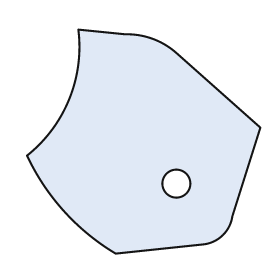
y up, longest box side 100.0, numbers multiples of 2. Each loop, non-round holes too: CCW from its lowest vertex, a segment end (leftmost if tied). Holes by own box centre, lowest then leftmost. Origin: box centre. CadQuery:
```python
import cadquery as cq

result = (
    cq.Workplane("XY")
    .moveTo(-12.0, -48.0)
    .lineTo(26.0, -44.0)
    .threePointArc((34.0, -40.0), (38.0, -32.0))
    .lineTo(50.0, 6.0)
    .lineTo(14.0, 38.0)
    .threePointArc((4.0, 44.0), (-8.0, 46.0))
    .lineTo(-28.0, 48.0)
    .threePointArc((-32.0, 18.0), (-50.0, -6.0))
    .threePointArc((-34.0, -30.0), (-12.0, -48.0))
    .close()
    .moveTo(14.0, -18.0)
    .circle(6.0)
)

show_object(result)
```